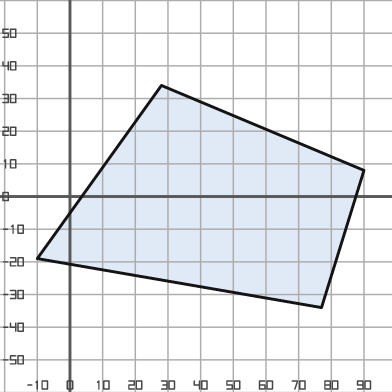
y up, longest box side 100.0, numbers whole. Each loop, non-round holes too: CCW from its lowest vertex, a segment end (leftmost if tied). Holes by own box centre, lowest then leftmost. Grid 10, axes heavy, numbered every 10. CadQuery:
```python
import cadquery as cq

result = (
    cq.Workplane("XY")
    .moveTo(77.0, -34.0)
    .lineTo(90.0, 8.0)
    .lineTo(28.0, 34.0)
    .lineTo(-10.0, -19.0)
    .close()
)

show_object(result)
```